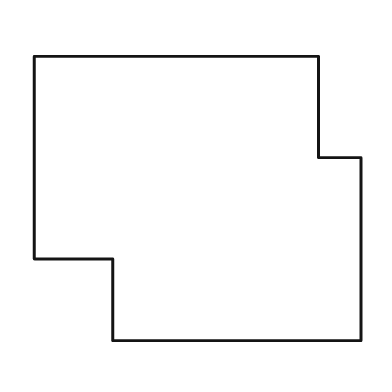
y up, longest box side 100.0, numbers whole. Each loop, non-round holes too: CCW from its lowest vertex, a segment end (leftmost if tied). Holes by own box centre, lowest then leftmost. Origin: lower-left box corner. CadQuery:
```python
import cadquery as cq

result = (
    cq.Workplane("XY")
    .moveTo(24.0, 0.0)
    .lineTo(100.0, 0.0)
    .lineTo(100.0, 56.0)
    .lineTo(87.0, 56.0)
    .lineTo(87.0, 87.0)
    .lineTo(0.0, 87.0)
    .lineTo(0.0, 25.0)
    .lineTo(24.0, 25.0)
    .close()
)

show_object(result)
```